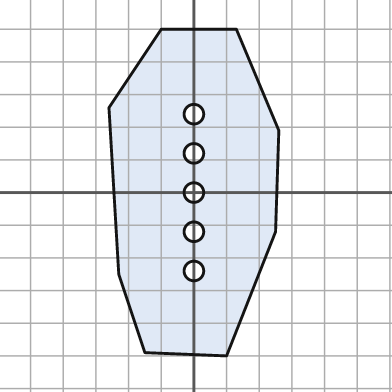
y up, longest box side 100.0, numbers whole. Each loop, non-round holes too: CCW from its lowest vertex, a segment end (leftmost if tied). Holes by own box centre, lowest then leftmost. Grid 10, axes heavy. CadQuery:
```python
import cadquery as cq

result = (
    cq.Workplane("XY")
    .moveTo(10.0, -50.0)
    .lineTo(25.0, -12.0)
    .lineTo(26.0, 19.0)
    .lineTo(13.0, 50.0)
    .lineTo(-10.0, 50.0)
    .lineTo(-26.0, 26.0)
    .lineTo(-23.0, -25.0)
    .lineTo(-15.0, -49.0)
    .close()
    .moveTo(0.0, -24.0)
    .circle(3.0)
    .moveTo(0.0, -12.0)
    .circle(3.0)
    .moveTo(0.0, 0.0)
    .circle(3.0)
    .moveTo(0.0, 12.0)
    .circle(3.0)
    .moveTo(0.0, 24.0)
    .circle(3.0)
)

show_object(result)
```